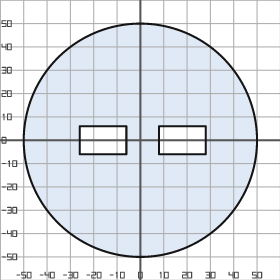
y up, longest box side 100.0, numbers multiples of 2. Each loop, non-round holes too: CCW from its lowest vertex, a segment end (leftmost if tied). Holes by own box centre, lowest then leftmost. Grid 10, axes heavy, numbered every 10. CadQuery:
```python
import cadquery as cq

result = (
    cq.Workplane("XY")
    .moveTo(0.0, 0.0)
    .circle(50.0)
    .moveTo(-26.0, -6.0)
    .lineTo(-6.0, -6.0)
    .lineTo(-6.0, 6.0)
    .lineTo(-26.0, 6.0)
    .close()
    .moveTo(8.0, -6.0)
    .lineTo(28.0, -6.0)
    .lineTo(28.0, 6.0)
    .lineTo(8.0, 6.0)
    .close()
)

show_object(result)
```